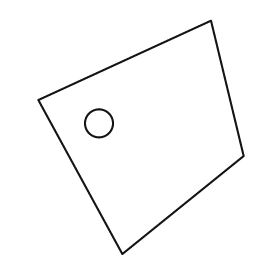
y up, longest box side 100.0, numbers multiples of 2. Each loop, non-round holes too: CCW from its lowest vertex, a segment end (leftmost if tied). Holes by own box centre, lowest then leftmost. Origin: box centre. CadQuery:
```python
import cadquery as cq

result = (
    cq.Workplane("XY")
    .moveTo(-8.0, -50.0)
    .lineTo(44.0, -8.0)
    .lineTo(30.0, 50.0)
    .lineTo(-44.0, 16.0)
    .close()
    .moveTo(-18.0, 6.0)
    .circle(6.0)
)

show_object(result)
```